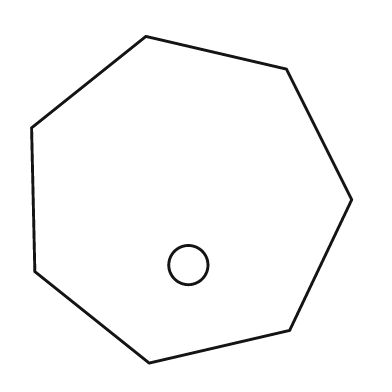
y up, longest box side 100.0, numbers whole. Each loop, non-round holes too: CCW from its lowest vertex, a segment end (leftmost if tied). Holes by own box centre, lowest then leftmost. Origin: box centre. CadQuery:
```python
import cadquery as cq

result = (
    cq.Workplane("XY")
    .moveTo(-13.0, -50.0)
    .lineTo(30.0, -40.0)
    .lineTo(49.0, 0.0)
    .lineTo(29.0, 40.0)
    .lineTo(-14.0, 50.0)
    .lineTo(-49.0, 22.0)
    .lineTo(-48.0, -22.0)
    .close()
    .moveTo(-1.0, -20.0)
    .circle(6.0)
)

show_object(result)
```